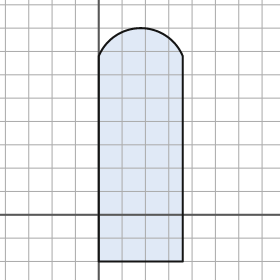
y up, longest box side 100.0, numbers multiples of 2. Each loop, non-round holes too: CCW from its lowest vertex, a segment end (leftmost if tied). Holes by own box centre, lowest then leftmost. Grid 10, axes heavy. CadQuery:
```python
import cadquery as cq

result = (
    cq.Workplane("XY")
    .moveTo(0.0, -20.0)
    .lineTo(36.0, -20.0)
    .lineTo(36.0, 68.0)
    .threePointArc((18.0, 80.0), (0.0, 68.0))
    .close()
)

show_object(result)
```